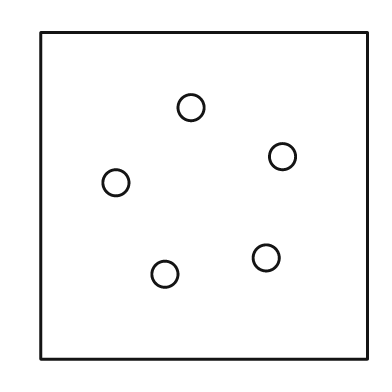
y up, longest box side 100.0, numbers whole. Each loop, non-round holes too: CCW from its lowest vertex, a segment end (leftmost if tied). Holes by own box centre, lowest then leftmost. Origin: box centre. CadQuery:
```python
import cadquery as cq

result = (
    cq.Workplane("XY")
    .moveTo(-50.0, -50.0)
    .lineTo(50.0, -50.0)
    .lineTo(50.0, 50.0)
    .lineTo(-50.0, 50.0)
    .close()
    .moveTo(-12.0, -24.0)
    .circle(4.0)
    .moveTo(19.0, -19.0)
    .circle(4.0)
    .moveTo(-27.0, 4.0)
    .circle(4.0)
    .moveTo(24.0, 12.0)
    .circle(4.0)
    .moveTo(-4.0, 27.0)
    .circle(4.0)
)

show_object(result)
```